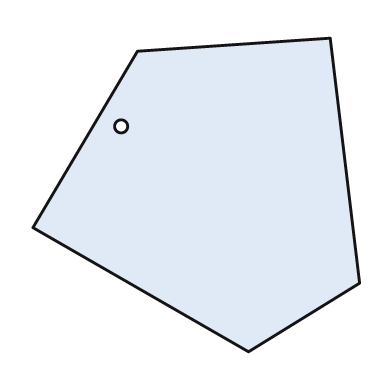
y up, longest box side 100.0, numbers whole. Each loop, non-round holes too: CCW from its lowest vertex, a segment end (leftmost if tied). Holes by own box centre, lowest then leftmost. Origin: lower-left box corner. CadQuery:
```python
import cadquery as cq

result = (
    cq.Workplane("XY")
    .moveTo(66.0, 0.0)
    .lineTo(100.0, 21.0)
    .lineTo(91.0, 96.0)
    .lineTo(32.0, 92.0)
    .lineTo(0.0, 38.0)
    .close()
    .moveTo(27.0, 69.0)
    .circle(2.0)
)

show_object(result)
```